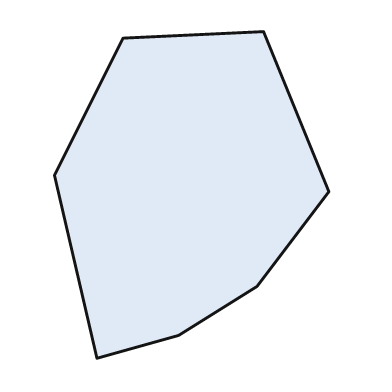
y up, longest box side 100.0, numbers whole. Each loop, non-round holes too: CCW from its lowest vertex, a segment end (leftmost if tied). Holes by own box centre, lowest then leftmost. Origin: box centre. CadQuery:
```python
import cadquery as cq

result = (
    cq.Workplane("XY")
    .moveTo(-29.0, -50.0)
    .lineTo(-4.0, -43.0)
    .lineTo(20.0, -28.0)
    .lineTo(42.0, 1.0)
    .lineTo(22.0, 50.0)
    .lineTo(-21.0, 48.0)
    .lineTo(-42.0, 6.0)
    .close()
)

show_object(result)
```